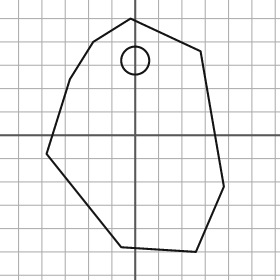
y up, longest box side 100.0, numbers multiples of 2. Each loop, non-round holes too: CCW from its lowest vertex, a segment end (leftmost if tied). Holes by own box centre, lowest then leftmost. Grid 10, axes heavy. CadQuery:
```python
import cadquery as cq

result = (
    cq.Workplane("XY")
    .moveTo(26.0, -50.0)
    .lineTo(38.0, -22.0)
    .lineTo(28.0, 36.0)
    .lineTo(-2.0, 50.0)
    .lineTo(-18.0, 40.0)
    .lineTo(-28.0, 24.0)
    .lineTo(-38.0, -8.0)
    .lineTo(-6.0, -48.0)
    .close()
    .moveTo(0.0, 32.0)
    .circle(6.0)
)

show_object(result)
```